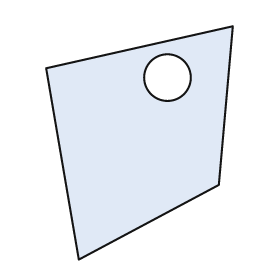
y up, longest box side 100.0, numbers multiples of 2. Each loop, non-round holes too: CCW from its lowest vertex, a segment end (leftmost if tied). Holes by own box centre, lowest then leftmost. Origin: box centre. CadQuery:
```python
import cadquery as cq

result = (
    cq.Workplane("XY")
    .moveTo(-26.0, -50.0)
    .lineTo(34.0, -18.0)
    .lineTo(40.0, 50.0)
    .lineTo(-40.0, 32.0)
    .close()
    .moveTo(12.0, 28.0)
    .circle(10.0)
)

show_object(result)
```